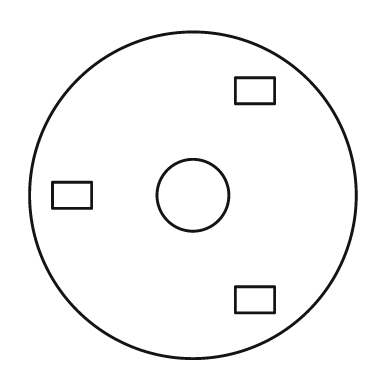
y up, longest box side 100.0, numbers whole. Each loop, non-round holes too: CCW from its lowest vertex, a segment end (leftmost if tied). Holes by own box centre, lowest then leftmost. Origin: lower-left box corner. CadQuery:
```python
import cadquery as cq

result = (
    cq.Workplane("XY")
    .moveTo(50.0, 50.0)
    .circle(50.0)
    .moveTo(63.0, 14.0)
    .lineTo(75.0, 14.0)
    .lineTo(75.0, 22.0)
    .lineTo(63.0, 22.0)
    .close()
    .moveTo(7.0, 46.0)
    .lineTo(19.0, 46.0)
    .lineTo(19.0, 54.0)
    .lineTo(7.0, 54.0)
    .close()
    .moveTo(50.0, 50.0)
    .circle(11.0)
    .moveTo(63.0, 78.0)
    .lineTo(75.0, 78.0)
    .lineTo(75.0, 86.0)
    .lineTo(63.0, 86.0)
    .close()
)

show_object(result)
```